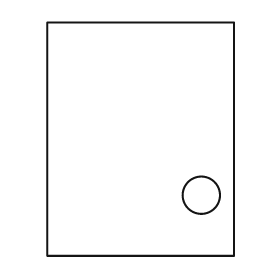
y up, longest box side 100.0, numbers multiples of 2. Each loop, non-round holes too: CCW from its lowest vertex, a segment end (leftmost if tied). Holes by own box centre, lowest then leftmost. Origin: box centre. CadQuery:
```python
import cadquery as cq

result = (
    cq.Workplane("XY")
    .moveTo(-40.0, -50.0)
    .lineTo(40.0, -50.0)
    .lineTo(40.0, 50.0)
    .lineTo(-40.0, 50.0)
    .close()
    .moveTo(26.0, -24.0)
    .circle(8.0)
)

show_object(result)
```